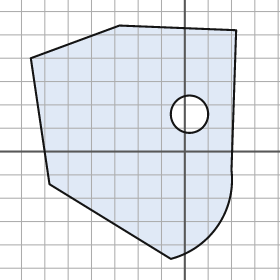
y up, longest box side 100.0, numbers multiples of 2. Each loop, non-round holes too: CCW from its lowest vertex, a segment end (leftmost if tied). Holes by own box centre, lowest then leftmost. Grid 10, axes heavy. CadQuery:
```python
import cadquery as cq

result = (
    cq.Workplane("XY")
    .moveTo(-6.0, -46.0)
    .threePointArc((14.0, -32.0), (20.0, -8.0))
    .lineTo(22.0, 52.0)
    .lineTo(-28.0, 54.0)
    .lineTo(-66.0, 40.0)
    .lineTo(-58.0, -14.0)
    .close()
    .moveTo(2.0, 16.0)
    .circle(8.0)
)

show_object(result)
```